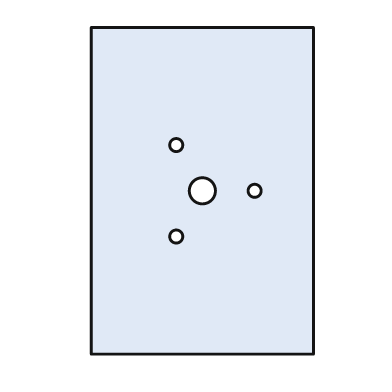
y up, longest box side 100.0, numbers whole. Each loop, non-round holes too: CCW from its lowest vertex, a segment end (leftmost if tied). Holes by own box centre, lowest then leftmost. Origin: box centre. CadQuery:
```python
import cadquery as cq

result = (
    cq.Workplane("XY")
    .moveTo(-34.0, -50.0)
    .lineTo(34.0, -50.0)
    .lineTo(34.0, 50.0)
    .lineTo(-34.0, 50.0)
    .close()
    .moveTo(-8.0, -14.0)
    .circle(2.0)
    .moveTo(0.0, 0.0)
    .circle(4.0)
    .moveTo(16.0, 0.0)
    .circle(2.0)
    .moveTo(-8.0, 14.0)
    .circle(2.0)
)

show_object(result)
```